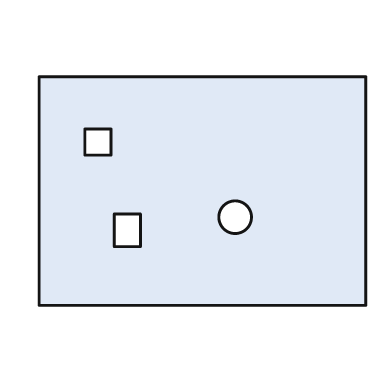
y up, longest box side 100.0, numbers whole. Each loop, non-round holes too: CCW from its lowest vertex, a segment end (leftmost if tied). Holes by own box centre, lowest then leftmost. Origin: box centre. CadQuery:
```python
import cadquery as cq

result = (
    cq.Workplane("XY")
    .moveTo(-50.0, -35.0)
    .lineTo(50.0, -35.0)
    .lineTo(50.0, 35.0)
    .lineTo(-50.0, 35.0)
    .close()
    .moveTo(-27.0, -17.0)
    .lineTo(-19.0, -17.0)
    .lineTo(-19.0, -7.0)
    .lineTo(-27.0, -7.0)
    .close()
    .moveTo(10.0, -8.0)
    .circle(5.0)
    .moveTo(-36.0, 11.0)
    .lineTo(-28.0, 11.0)
    .lineTo(-28.0, 19.0)
    .lineTo(-36.0, 19.0)
    .close()
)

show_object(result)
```